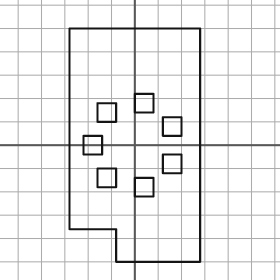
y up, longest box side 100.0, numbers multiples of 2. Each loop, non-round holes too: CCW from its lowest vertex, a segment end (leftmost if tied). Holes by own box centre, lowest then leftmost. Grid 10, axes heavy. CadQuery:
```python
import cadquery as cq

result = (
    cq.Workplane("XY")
    .moveTo(-8.0, -50.0)
    .lineTo(28.0, -50.0)
    .lineTo(28.0, 50.0)
    .lineTo(-28.0, 50.0)
    .lineTo(-28.0, -36.0)
    .lineTo(-8.0, -36.0)
    .close()
    .moveTo(0.0, -22.0)
    .lineTo(8.0, -22.0)
    .lineTo(8.0, -14.0)
    .lineTo(0.0, -14.0)
    .close()
    .moveTo(-16.0, -18.0)
    .lineTo(-8.0, -18.0)
    .lineTo(-8.0, -10.0)
    .lineTo(-16.0, -10.0)
    .close()
    .moveTo(12.0, -12.0)
    .lineTo(20.0, -12.0)
    .lineTo(20.0, -4.0)
    .lineTo(12.0, -4.0)
    .close()
    .moveTo(-22.0, -4.0)
    .lineTo(-14.0, -4.0)
    .lineTo(-14.0, 4.0)
    .lineTo(-22.0, 4.0)
    .close()
    .moveTo(12.0, 4.0)
    .lineTo(20.0, 4.0)
    .lineTo(20.0, 12.0)
    .lineTo(12.0, 12.0)
    .close()
    .moveTo(-16.0, 10.0)
    .lineTo(-8.0, 10.0)
    .lineTo(-8.0, 18.0)
    .lineTo(-16.0, 18.0)
    .close()
    .moveTo(0.0, 14.0)
    .lineTo(8.0, 14.0)
    .lineTo(8.0, 22.0)
    .lineTo(0.0, 22.0)
    .close()
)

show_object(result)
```